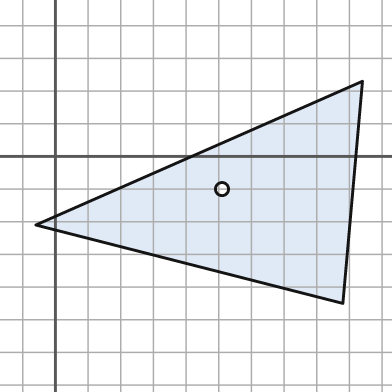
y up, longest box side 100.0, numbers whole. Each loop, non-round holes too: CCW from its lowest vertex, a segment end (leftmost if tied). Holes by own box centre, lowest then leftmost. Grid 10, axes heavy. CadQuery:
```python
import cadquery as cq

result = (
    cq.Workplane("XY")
    .moveTo(88.0, -45.0)
    .lineTo(94.0, 23.0)
    .lineTo(-6.0, -21.0)
    .close()
    .moveTo(51.0, -10.0)
    .circle(2.0)
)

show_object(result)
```